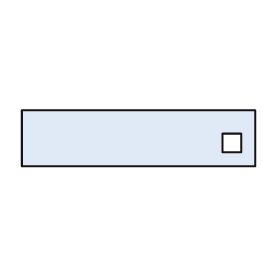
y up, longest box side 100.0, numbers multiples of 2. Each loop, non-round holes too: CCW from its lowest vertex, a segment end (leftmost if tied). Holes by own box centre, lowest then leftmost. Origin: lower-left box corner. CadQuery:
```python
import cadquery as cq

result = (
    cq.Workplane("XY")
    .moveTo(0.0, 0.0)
    .lineTo(100.0, 0.0)
    .lineTo(100.0, 24.0)
    .lineTo(0.0, 24.0)
    .close()
    .moveTo(86.0, 6.0)
    .lineTo(94.0, 6.0)
    .lineTo(94.0, 14.0)
    .lineTo(86.0, 14.0)
    .close()
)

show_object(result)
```